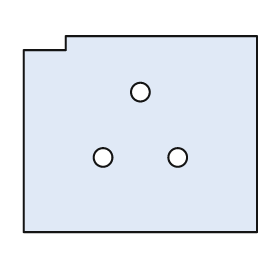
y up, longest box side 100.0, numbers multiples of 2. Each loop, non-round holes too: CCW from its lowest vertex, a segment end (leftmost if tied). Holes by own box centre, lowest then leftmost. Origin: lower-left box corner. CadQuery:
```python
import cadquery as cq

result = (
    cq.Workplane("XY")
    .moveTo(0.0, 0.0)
    .lineTo(100.0, 0.0)
    .lineTo(100.0, 84.0)
    .lineTo(18.0, 84.0)
    .lineTo(18.0, 78.0)
    .lineTo(0.0, 78.0)
    .close()
    .moveTo(34.0, 32.0)
    .circle(4.0)
    .moveTo(66.0, 32.0)
    .circle(4.0)
    .moveTo(50.0, 60.0)
    .circle(4.0)
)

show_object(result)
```